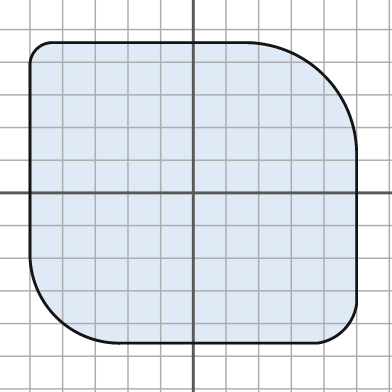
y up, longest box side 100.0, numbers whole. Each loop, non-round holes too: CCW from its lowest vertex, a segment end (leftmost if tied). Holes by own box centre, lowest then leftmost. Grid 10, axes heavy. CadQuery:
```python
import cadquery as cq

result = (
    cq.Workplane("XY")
    .moveTo(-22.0, -46.0)
    .lineTo(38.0, -46.0)
    .threePointArc((46.0, -42.0), (50.0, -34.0))
    .lineTo(50.0, 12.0)
    .threePointArc((40.0, 36.0), (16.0, 46.0))
    .lineTo(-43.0, 46.0)
    .threePointArc((-48.0, 44.0), (-50.0, 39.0))
    .lineTo(-50.0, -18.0)
    .threePointArc((-42.0, -38.0), (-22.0, -46.0))
    .close()
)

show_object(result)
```